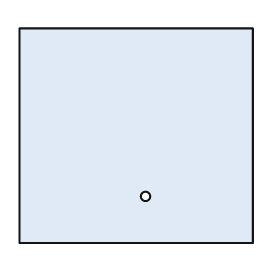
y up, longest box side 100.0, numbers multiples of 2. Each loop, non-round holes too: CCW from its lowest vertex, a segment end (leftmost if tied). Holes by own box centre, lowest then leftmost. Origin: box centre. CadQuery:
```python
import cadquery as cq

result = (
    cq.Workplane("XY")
    .moveTo(-50.0, -46.0)
    .lineTo(50.0, -46.0)
    .lineTo(50.0, 46.0)
    .lineTo(-50.0, 46.0)
    .close()
    .moveTo(4.0, -26.0)
    .circle(2.0)
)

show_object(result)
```